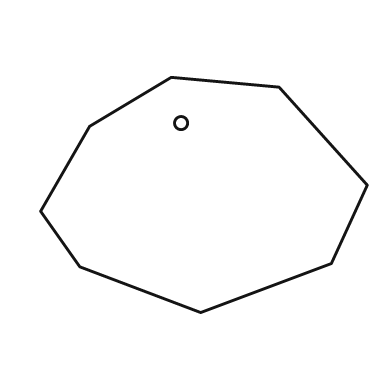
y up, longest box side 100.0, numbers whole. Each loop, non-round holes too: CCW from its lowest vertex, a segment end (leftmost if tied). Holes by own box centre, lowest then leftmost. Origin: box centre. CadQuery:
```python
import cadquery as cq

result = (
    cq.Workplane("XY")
    .moveTo(-1.0, -36.0)
    .lineTo(39.0, -21.0)
    .lineTo(50.0, 3.0)
    .lineTo(23.0, 33.0)
    .lineTo(-10.0, 36.0)
    .lineTo(-35.0, 21.0)
    .lineTo(-50.0, -5.0)
    .lineTo(-38.0, -22.0)
    .close()
    .moveTo(-7.0, 22.0)
    .circle(2.0)
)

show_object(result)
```